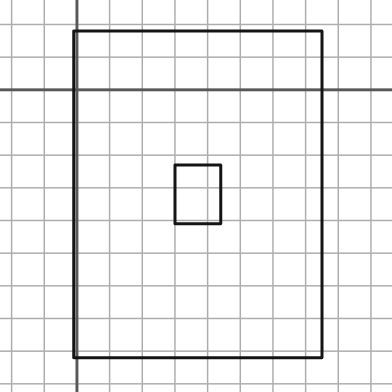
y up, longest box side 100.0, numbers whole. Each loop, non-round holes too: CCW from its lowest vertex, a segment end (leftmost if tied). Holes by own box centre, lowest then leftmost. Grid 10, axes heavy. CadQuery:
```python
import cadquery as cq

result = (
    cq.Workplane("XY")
    .moveTo(-1.0, -82.0)
    .lineTo(75.0, -82.0)
    .lineTo(75.0, 18.0)
    .lineTo(-1.0, 18.0)
    .close()
    .moveTo(30.0, -41.0)
    .lineTo(44.0, -41.0)
    .lineTo(44.0, -23.0)
    .lineTo(30.0, -23.0)
    .close()
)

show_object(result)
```